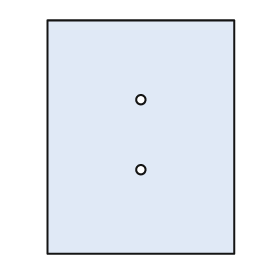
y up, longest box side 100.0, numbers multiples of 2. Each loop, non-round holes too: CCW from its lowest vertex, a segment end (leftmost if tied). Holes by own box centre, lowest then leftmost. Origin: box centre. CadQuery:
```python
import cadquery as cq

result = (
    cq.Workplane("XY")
    .moveTo(-40.0, -50.0)
    .lineTo(40.0, -50.0)
    .lineTo(40.0, 50.0)
    .lineTo(-40.0, 50.0)
    .close()
    .moveTo(0.0, -14.0)
    .circle(2.0)
    .moveTo(0.0, 16.0)
    .circle(2.0)
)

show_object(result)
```